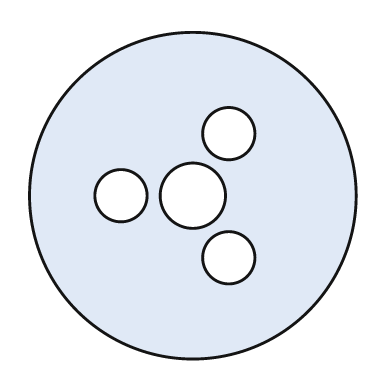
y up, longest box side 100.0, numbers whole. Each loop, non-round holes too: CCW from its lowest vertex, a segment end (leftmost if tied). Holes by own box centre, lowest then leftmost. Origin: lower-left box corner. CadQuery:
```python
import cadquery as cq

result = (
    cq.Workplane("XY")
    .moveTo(50.0, 50.0)
    .circle(50.0)
    .moveTo(61.0, 31.0)
    .circle(8.0)
    .moveTo(28.0, 50.0)
    .circle(8.0)
    .moveTo(50.0, 50.0)
    .circle(10.0)
    .moveTo(61.0, 69.0)
    .circle(8.0)
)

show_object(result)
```